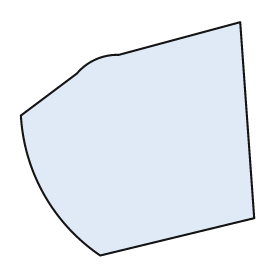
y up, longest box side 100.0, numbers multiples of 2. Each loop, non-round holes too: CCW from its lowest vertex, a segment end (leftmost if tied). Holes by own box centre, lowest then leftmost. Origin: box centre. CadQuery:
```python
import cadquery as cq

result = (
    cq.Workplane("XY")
    .moveTo(-16.0, -50.0)
    .lineTo(50.0, -34.0)
    .lineTo(44.0, 50.0)
    .lineTo(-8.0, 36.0)
    .threePointArc((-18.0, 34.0), (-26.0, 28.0))
    .lineTo(-50.0, 10.0)
    .threePointArc((-40.0, -24.0), (-16.0, -50.0))
    .close()
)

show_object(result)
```